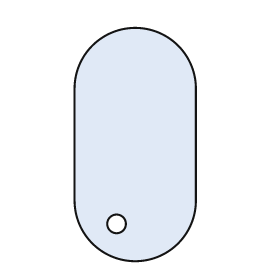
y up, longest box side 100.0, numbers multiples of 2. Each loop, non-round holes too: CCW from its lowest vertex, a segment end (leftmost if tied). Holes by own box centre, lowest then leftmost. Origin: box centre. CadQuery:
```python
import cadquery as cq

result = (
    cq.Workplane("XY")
    .moveTo(-26.0, -24.0)
    .threePointArc((0.0, -50.0), (26.0, -24.0))
    .lineTo(26.0, 24.0)
    .threePointArc((0.0, 50.0), (-26.0, 24.0))
    .close()
    .moveTo(-8.0, -34.0)
    .circle(4.0)
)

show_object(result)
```